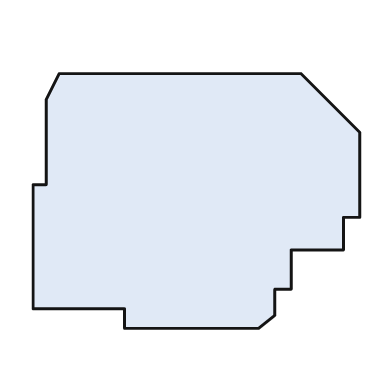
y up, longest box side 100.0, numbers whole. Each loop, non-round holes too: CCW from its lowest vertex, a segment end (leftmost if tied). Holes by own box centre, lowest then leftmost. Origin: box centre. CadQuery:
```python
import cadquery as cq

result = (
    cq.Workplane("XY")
    .moveTo(-22.0, -39.0)
    .lineTo(19.0, -39.0)
    .lineTo(24.0, -35.0)
    .lineTo(24.0, -27.0)
    .lineTo(29.0, -27.0)
    .lineTo(29.0, -15.0)
    .lineTo(45.0, -15.0)
    .lineTo(45.0, -5.0)
    .lineTo(50.0, -5.0)
    .lineTo(50.0, 21.0)
    .lineTo(32.0, 39.0)
    .lineTo(-42.0, 39.0)
    .lineTo(-46.0, 31.0)
    .lineTo(-46.0, 5.0)
    .lineTo(-50.0, 5.0)
    .lineTo(-50.0, -33.0)
    .lineTo(-22.0, -33.0)
    .close()
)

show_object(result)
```